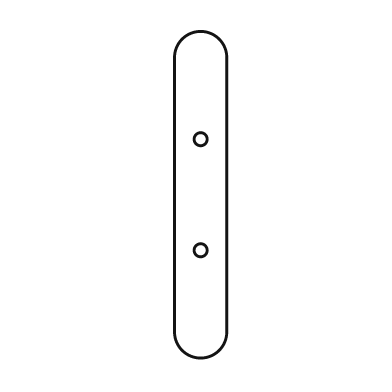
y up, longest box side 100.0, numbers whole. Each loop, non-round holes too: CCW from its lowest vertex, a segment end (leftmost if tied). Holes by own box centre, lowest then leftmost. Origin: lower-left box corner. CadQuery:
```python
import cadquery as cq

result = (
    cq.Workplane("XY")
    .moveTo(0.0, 8.0)
    .threePointArc((8.0, 0.0), (16.0, 8.0))
    .lineTo(16.0, 92.0)
    .threePointArc((8.0, 100.0), (0.0, 92.0))
    .close()
    .moveTo(8.0, 33.0)
    .circle(2.0)
    .moveTo(8.0, 67.0)
    .circle(2.0)
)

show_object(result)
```